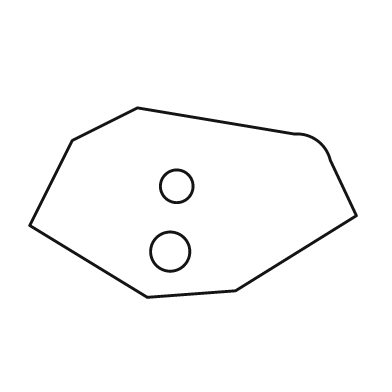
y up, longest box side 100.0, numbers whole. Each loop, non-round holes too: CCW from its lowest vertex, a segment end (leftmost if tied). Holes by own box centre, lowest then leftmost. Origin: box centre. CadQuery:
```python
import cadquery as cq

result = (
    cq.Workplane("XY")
    .moveTo(-14.0, -29.0)
    .lineTo(13.0, -27.0)
    .lineTo(50.0, -4.0)
    .lineTo(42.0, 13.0)
    .threePointArc((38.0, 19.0), (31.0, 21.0))
    .lineTo(-17.0, 29.0)
    .lineTo(-37.0, 19.0)
    .lineTo(-50.0, -7.0)
    .close()
    .moveTo(-7.0, -15.0)
    .circle(6.0)
    .moveTo(-5.0, 5.0)
    .circle(5.0)
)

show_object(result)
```